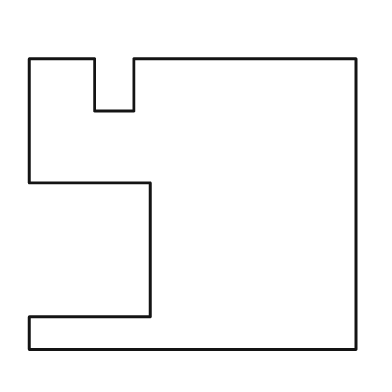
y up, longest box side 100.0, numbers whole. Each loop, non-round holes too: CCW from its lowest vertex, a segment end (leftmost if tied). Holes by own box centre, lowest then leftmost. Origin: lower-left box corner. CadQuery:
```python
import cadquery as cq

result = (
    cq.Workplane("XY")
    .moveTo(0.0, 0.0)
    .lineTo(100.0, 0.0)
    .lineTo(100.0, 89.0)
    .lineTo(32.0, 89.0)
    .lineTo(32.0, 73.0)
    .lineTo(20.0, 73.0)
    .lineTo(20.0, 89.0)
    .lineTo(0.0, 89.0)
    .lineTo(0.0, 51.0)
    .lineTo(37.0, 51.0)
    .lineTo(37.0, 10.0)
    .lineTo(0.0, 10.0)
    .close()
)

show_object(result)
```